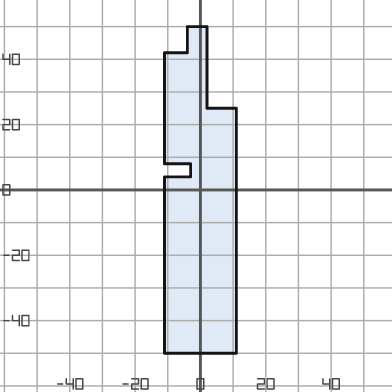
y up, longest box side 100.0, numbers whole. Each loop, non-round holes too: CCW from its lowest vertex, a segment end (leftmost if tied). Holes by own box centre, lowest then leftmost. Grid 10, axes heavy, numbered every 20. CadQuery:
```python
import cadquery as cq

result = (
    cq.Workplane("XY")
    .moveTo(-11.0, -50.0)
    .lineTo(11.0, -50.0)
    .lineTo(11.0, 25.0)
    .lineTo(2.0, 25.0)
    .lineTo(2.0, 50.0)
    .lineTo(-4.0, 50.0)
    .lineTo(-4.0, 42.0)
    .lineTo(-11.0, 42.0)
    .lineTo(-11.0, 8.0)
    .lineTo(-3.0, 8.0)
    .lineTo(-3.0, 4.0)
    .lineTo(-11.0, 4.0)
    .close()
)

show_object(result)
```